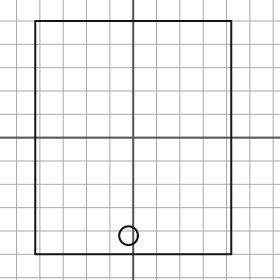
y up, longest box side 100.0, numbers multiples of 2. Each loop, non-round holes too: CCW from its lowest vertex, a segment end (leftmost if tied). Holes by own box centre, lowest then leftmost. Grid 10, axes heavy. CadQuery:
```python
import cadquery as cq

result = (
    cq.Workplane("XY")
    .moveTo(-42.0, -50.0)
    .lineTo(42.0, -50.0)
    .lineTo(42.0, 50.0)
    .lineTo(-42.0, 50.0)
    .close()
    .moveTo(-2.0, -42.0)
    .circle(4.0)
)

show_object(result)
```